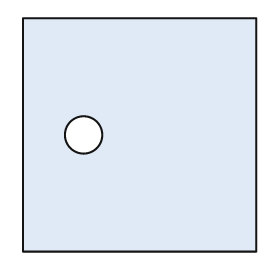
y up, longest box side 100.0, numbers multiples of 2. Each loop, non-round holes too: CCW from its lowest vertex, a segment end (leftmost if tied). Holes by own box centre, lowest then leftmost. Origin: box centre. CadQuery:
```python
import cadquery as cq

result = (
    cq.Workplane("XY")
    .moveTo(-50.0, -50.0)
    .lineTo(50.0, -50.0)
    .lineTo(50.0, 50.0)
    .lineTo(-50.0, 50.0)
    .close()
    .moveTo(-24.0, 0.0)
    .circle(8.0)
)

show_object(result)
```